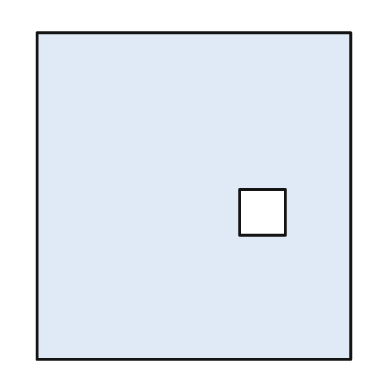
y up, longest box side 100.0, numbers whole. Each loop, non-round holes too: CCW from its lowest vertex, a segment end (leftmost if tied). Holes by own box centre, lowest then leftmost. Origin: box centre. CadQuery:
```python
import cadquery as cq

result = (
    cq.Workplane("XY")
    .moveTo(-48.0, -50.0)
    .lineTo(48.0, -50.0)
    .lineTo(48.0, 50.0)
    .lineTo(-48.0, 50.0)
    .close()
    .moveTo(14.0, -12.0)
    .lineTo(28.0, -12.0)
    .lineTo(28.0, 2.0)
    .lineTo(14.0, 2.0)
    .close()
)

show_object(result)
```